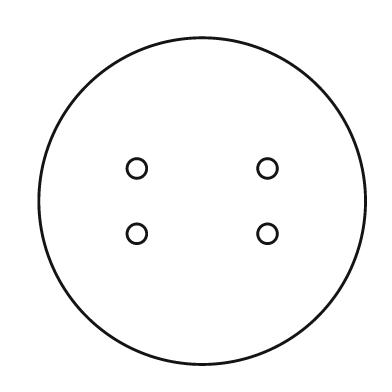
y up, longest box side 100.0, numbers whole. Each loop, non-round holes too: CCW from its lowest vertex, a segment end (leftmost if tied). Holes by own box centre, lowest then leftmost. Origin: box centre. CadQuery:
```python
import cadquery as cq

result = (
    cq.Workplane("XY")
    .moveTo(0.0, 0.0)
    .circle(50.0)
    .moveTo(-20.0, -10.0)
    .circle(3.0)
    .moveTo(20.0, -10.0)
    .circle(3.0)
    .moveTo(-20.0, 10.0)
    .circle(3.0)
    .moveTo(20.0, 10.0)
    .circle(3.0)
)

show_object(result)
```